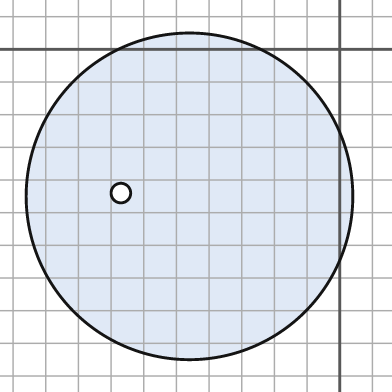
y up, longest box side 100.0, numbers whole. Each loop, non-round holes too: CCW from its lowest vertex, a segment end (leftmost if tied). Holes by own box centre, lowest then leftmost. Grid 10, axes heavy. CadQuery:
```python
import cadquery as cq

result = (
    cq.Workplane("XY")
    .moveTo(-46.0, -45.0)
    .circle(50.0)
    .moveTo(-67.0, -44.0)
    .circle(3.0)
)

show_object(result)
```